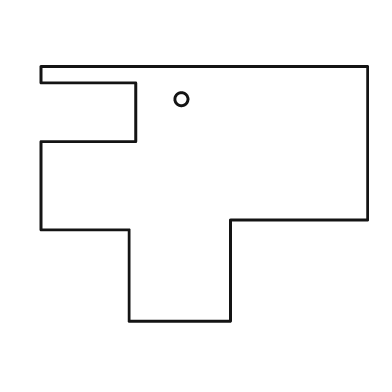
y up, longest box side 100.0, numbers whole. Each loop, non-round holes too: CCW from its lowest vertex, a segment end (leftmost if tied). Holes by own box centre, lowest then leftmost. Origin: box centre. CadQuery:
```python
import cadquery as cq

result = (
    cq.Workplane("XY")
    .moveTo(-23.0, -39.0)
    .lineTo(8.0, -39.0)
    .lineTo(8.0, -8.0)
    .lineTo(50.0, -8.0)
    .lineTo(50.0, 39.0)
    .lineTo(-50.0, 39.0)
    .lineTo(-50.0, 34.0)
    .lineTo(-21.0, 34.0)
    .lineTo(-21.0, 16.0)
    .lineTo(-50.0, 16.0)
    .lineTo(-50.0, -11.0)
    .lineTo(-23.0, -11.0)
    .close()
    .moveTo(-7.0, 29.0)
    .circle(2.0)
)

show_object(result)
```